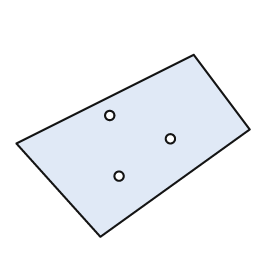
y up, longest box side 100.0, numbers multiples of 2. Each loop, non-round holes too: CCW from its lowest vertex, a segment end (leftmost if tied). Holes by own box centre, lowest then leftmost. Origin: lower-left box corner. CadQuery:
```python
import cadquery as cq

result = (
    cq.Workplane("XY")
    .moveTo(36.0, 0.0)
    .lineTo(100.0, 46.0)
    .lineTo(76.0, 78.0)
    .lineTo(0.0, 40.0)
    .close()
    .moveTo(44.0, 26.0)
    .circle(2.0)
    .moveTo(66.0, 42.0)
    .circle(2.0)
    .moveTo(40.0, 52.0)
    .circle(2.0)
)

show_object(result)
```